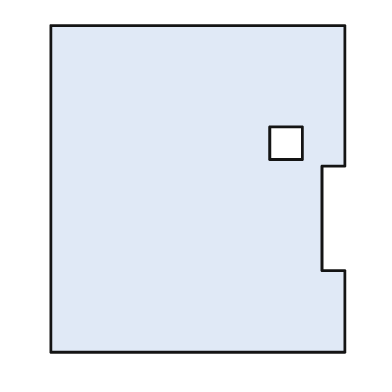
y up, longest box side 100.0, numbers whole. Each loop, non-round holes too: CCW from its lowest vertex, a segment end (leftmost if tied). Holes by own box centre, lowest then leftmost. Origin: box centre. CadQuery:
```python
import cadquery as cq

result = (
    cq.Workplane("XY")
    .moveTo(-45.0, -50.0)
    .lineTo(45.0, -50.0)
    .lineTo(45.0, -25.0)
    .lineTo(38.0, -25.0)
    .lineTo(38.0, 7.0)
    .lineTo(45.0, 7.0)
    .lineTo(45.0, 50.0)
    .lineTo(-45.0, 50.0)
    .close()
    .moveTo(22.0, 9.0)
    .lineTo(32.0, 9.0)
    .lineTo(32.0, 19.0)
    .lineTo(22.0, 19.0)
    .close()
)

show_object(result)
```